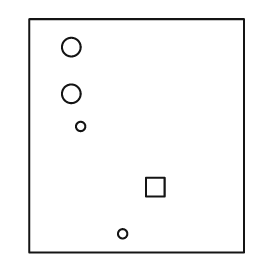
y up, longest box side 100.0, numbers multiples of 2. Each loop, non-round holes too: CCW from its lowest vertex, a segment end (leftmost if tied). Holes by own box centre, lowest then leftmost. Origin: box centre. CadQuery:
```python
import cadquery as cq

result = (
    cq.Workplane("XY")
    .moveTo(-46.0, -50.0)
    .lineTo(46.0, -50.0)
    .lineTo(46.0, 50.0)
    .lineTo(-46.0, 50.0)
    .close()
    .moveTo(-6.0, -42.0)
    .circle(2.0)
    .moveTo(4.0, -26.0)
    .lineTo(12.0, -26.0)
    .lineTo(12.0, -18.0)
    .lineTo(4.0, -18.0)
    .close()
    .moveTo(-24.0, 4.0)
    .circle(2.0)
    .moveTo(-28.0, 18.0)
    .circle(4.0)
    .moveTo(-28.0, 38.0)
    .circle(4.0)
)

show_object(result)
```